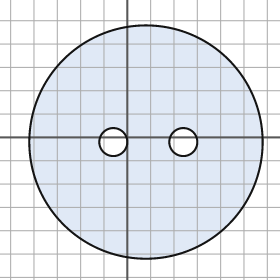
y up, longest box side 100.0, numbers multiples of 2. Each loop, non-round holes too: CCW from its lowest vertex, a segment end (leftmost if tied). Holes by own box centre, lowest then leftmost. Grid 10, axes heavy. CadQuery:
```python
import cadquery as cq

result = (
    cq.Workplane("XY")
    .moveTo(8.0, -2.0)
    .circle(50.0)
    .moveTo(-6.0, -2.0)
    .circle(6.0)
    .moveTo(24.0, -2.0)
    .circle(6.0)
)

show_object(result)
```